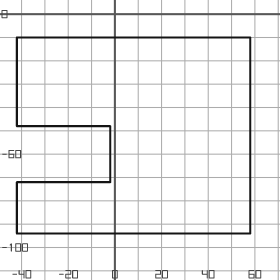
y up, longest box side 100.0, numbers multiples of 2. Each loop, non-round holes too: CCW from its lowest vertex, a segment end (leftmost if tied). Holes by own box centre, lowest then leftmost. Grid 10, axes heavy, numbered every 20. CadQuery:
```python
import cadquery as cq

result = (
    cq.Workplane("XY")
    .moveTo(-42.0, -94.0)
    .lineTo(58.0, -94.0)
    .lineTo(58.0, -10.0)
    .lineTo(-42.0, -10.0)
    .lineTo(-42.0, -48.0)
    .lineTo(-2.0, -48.0)
    .lineTo(-2.0, -72.0)
    .lineTo(-42.0, -72.0)
    .close()
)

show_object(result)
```